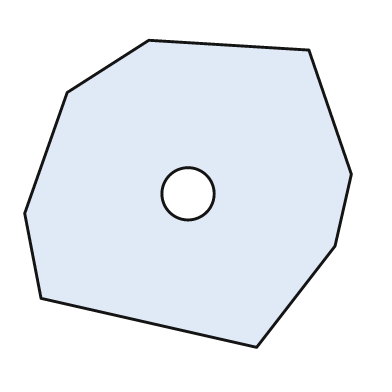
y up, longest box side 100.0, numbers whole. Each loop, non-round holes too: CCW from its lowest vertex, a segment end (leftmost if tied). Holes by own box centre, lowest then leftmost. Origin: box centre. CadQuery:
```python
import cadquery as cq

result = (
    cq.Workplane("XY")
    .moveTo(21.0, -47.0)
    .lineTo(45.0, -16.0)
    .lineTo(50.0, 6.0)
    .lineTo(37.0, 44.0)
    .lineTo(-12.0, 47.0)
    .lineTo(-37.0, 31.0)
    .lineTo(-50.0, -6.0)
    .lineTo(-45.0, -32.0)
    .close()
    .moveTo(0.0, 0.0)
    .circle(8.0)
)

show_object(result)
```